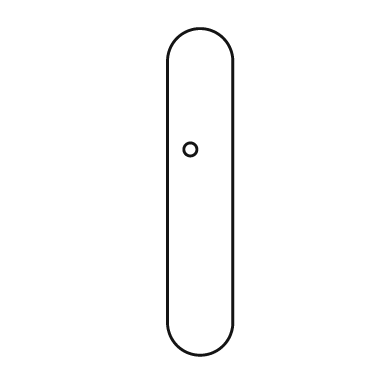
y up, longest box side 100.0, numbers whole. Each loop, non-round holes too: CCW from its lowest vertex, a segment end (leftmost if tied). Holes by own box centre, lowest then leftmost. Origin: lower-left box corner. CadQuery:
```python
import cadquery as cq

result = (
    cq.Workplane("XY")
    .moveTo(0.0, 10.0)
    .threePointArc((10.0, 0.0), (20.0, 10.0))
    .lineTo(20.0, 90.0)
    .threePointArc((10.0, 100.0), (0.0, 90.0))
    .close()
    .moveTo(7.0, 63.0)
    .circle(2.0)
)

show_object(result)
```